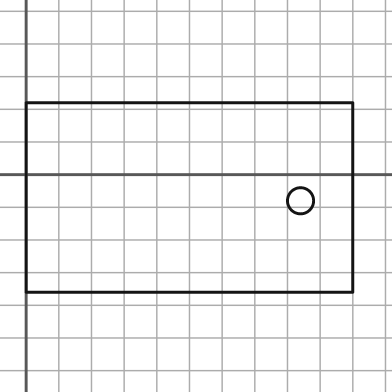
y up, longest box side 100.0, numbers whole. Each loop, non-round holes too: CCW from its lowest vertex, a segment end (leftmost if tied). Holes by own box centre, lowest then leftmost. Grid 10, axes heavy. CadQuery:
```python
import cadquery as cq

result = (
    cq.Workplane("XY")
    .moveTo(0.0, -36.0)
    .lineTo(100.0, -36.0)
    .lineTo(100.0, 22.0)
    .lineTo(0.0, 22.0)
    .close()
    .moveTo(84.0, -8.0)
    .circle(4.0)
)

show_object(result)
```